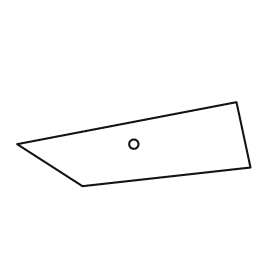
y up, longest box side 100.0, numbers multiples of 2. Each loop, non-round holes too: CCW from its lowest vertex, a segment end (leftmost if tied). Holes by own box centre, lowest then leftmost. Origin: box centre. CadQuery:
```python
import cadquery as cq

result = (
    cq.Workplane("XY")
    .moveTo(-22.0, -18.0)
    .lineTo(50.0, -10.0)
    .lineTo(44.0, 18.0)
    .lineTo(-50.0, 0.0)
    .close()
    .moveTo(0.0, 0.0)
    .circle(2.0)
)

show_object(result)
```